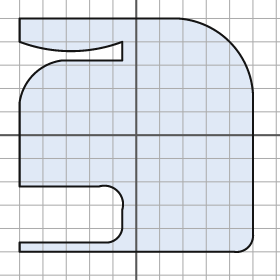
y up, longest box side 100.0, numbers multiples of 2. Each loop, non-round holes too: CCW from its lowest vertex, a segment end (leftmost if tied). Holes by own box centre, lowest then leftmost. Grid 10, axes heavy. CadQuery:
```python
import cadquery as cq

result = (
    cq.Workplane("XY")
    .moveTo(-50.0, -50.0)
    .lineTo(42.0, -50.0)
    .threePointArc((48.0, -48.0), (50.0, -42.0))
    .lineTo(50.0, 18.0)
    .threePointArc((40.0, 40.0), (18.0, 50.0))
    .lineTo(-50.0, 50.0)
    .lineTo(-50.0, 40.0)
    .threePointArc((-28.0, 36.0), (-6.0, 40.0))
    .lineTo(-6.0, 32.0)
    .lineTo(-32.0, 32.0)
    .threePointArc((-44.0, 26.0), (-50.0, 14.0))
    .lineTo(-50.0, -22.0)
    .lineTo(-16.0, -22.0)
    .threePointArc((-8.0, -24.0), (-6.0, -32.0))
    .lineTo(-6.0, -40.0)
    .threePointArc((-8.0, -44.0), (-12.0, -46.0))
    .lineTo(-50.0, -46.0)
    .close()
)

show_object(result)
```